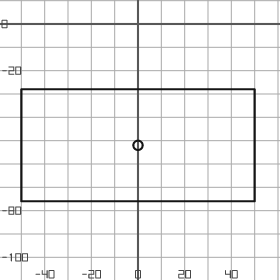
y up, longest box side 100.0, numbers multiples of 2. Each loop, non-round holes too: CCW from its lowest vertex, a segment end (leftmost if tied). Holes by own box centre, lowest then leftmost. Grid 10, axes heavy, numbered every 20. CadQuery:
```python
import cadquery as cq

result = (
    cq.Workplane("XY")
    .moveTo(-50.0, -76.0)
    .lineTo(50.0, -76.0)
    .lineTo(50.0, -28.0)
    .lineTo(-50.0, -28.0)
    .close()
    .moveTo(0.0, -52.0)
    .circle(2.0)
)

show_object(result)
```